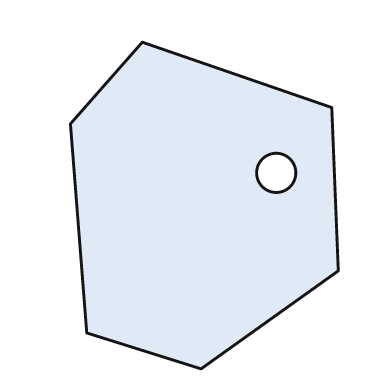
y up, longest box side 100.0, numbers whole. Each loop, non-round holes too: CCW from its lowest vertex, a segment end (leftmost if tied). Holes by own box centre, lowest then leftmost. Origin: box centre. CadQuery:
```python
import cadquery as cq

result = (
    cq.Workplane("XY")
    .moveTo(-1.0, -50.0)
    .lineTo(41.0, -20.0)
    .lineTo(39.0, 30.0)
    .lineTo(-19.0, 50.0)
    .lineTo(-41.0, 25.0)
    .lineTo(-36.0, -39.0)
    .close()
    .moveTo(22.0, 10.0)
    .circle(6.0)
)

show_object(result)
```